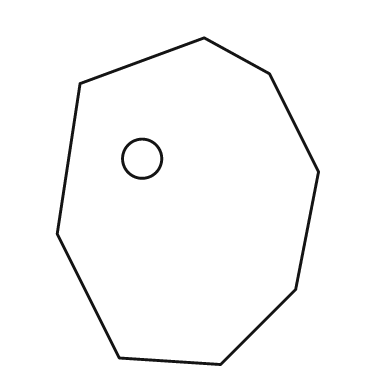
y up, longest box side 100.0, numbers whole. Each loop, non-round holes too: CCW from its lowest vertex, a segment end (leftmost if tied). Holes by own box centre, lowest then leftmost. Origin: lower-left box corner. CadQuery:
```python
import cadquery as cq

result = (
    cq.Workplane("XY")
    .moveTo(50.0, 0.0)
    .lineTo(73.0, 23.0)
    .lineTo(80.0, 59.0)
    .lineTo(65.0, 89.0)
    .lineTo(45.0, 100.0)
    .lineTo(7.0, 86.0)
    .lineTo(0.0, 40.0)
    .lineTo(19.0, 2.0)
    .close()
    .moveTo(26.0, 63.0)
    .circle(6.0)
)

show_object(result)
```